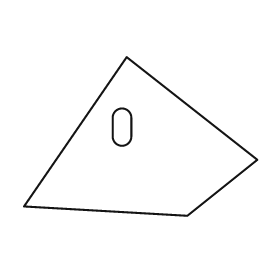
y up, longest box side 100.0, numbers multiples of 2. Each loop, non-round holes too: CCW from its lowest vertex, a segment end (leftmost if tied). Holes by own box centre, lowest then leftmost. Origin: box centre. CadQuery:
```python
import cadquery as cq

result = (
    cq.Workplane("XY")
    .moveTo(20.0, -34.0)
    .lineTo(50.0, -10.0)
    .lineTo(-6.0, 34.0)
    .lineTo(-50.0, -30.0)
    .close()
    .moveTo(-12.0, 0.0)
    .threePointArc((-8.0, -4.0), (-4.0, 0.0))
    .lineTo(-4.0, 8.0)
    .threePointArc((-8.0, 12.0), (-12.0, 8.0))
    .close()
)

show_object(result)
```